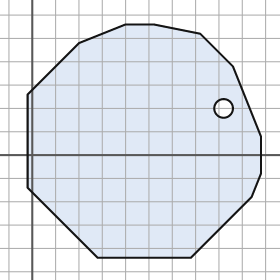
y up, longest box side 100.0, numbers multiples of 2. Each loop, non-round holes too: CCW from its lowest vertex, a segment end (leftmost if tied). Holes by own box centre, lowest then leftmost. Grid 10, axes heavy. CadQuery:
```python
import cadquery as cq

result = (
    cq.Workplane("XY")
    .moveTo(28.0, -44.0)
    .lineTo(68.0, -44.0)
    .lineTo(94.0, -18.0)
    .lineTo(98.0, -8.0)
    .lineTo(98.0, 8.0)
    .lineTo(86.0, 38.0)
    .lineTo(72.0, 52.0)
    .lineTo(52.0, 56.0)
    .lineTo(40.0, 56.0)
    .lineTo(20.0, 48.0)
    .lineTo(-2.0, 26.0)
    .lineTo(-2.0, -14.0)
    .close()
    .moveTo(82.0, 20.0)
    .circle(4.0)
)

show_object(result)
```